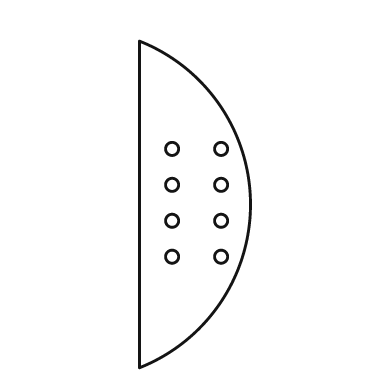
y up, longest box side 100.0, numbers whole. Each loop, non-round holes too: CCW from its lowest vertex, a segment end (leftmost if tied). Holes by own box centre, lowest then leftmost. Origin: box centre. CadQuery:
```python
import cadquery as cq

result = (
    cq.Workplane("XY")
    .moveTo(-17.0, -50.0)
    .threePointArc((17.0, 0.0), (-17.0, 50.0))
    .close()
    .moveTo(-7.0, -16.0)
    .circle(2.0)
    .moveTo(8.0, -16.0)
    .circle(2.0)
    .moveTo(-7.0, -5.0)
    .circle(2.0)
    .moveTo(8.0, -5.0)
    .circle(2.0)
    .moveTo(-7.0, 6.0)
    .circle(2.0)
    .moveTo(8.0, 6.0)
    .circle(2.0)
    .moveTo(-7.0, 17.0)
    .circle(2.0)
    .moveTo(8.0, 17.0)
    .circle(2.0)
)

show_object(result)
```